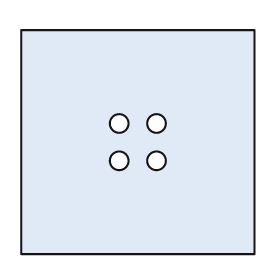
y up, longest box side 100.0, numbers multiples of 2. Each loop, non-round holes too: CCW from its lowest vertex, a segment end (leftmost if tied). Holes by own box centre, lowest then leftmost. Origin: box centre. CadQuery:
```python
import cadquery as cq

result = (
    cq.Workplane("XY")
    .moveTo(-50.0, -48.0)
    .lineTo(50.0, -48.0)
    .lineTo(50.0, 48.0)
    .lineTo(-50.0, 48.0)
    .close()
    .moveTo(-8.0, -8.0)
    .circle(4.0)
    .moveTo(8.0, -8.0)
    .circle(4.0)
    .moveTo(-8.0, 8.0)
    .circle(4.0)
    .moveTo(8.0, 8.0)
    .circle(4.0)
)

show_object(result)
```